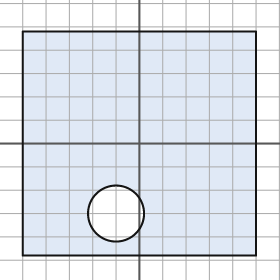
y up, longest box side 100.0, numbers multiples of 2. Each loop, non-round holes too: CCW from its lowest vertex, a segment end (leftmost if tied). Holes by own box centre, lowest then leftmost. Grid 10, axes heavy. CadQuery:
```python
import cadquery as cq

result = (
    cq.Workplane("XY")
    .moveTo(-50.0, -48.0)
    .lineTo(50.0, -48.0)
    .lineTo(50.0, 48.0)
    .lineTo(-50.0, 48.0)
    .close()
    .moveTo(-10.0, -30.0)
    .circle(12.0)
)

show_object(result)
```